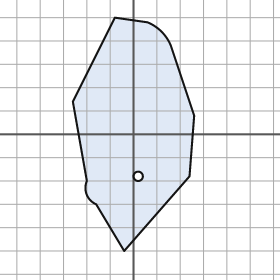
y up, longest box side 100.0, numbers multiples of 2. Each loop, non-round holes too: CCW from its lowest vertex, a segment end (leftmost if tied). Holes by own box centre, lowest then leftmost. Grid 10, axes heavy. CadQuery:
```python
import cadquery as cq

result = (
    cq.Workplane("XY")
    .moveTo(-4.0, -50.0)
    .lineTo(24.0, -18.0)
    .lineTo(26.0, 8.0)
    .lineTo(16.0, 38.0)
    .threePointArc((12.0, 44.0), (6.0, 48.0))
    .lineTo(-8.0, 50.0)
    .lineTo(-26.0, 14.0)
    .lineTo(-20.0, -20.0)
    .threePointArc((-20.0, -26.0), (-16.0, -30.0))
    .close()
    .moveTo(2.0, -18.0)
    .circle(2.0)
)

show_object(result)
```